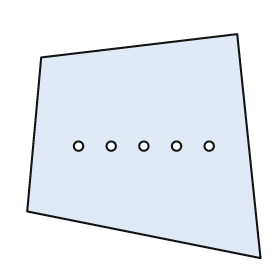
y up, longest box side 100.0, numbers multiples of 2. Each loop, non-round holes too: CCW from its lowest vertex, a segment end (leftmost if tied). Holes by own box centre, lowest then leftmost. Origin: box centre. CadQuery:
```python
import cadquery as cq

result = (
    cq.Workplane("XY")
    .moveTo(50.0, -48.0)
    .lineTo(40.0, 48.0)
    .lineTo(-44.0, 38.0)
    .lineTo(-50.0, -28.0)
    .close()
    .moveTo(-28.0, 0.0)
    .circle(2.0)
    .moveTo(-14.0, 0.0)
    .circle(2.0)
    .moveTo(0.0, 0.0)
    .circle(2.0)
    .moveTo(14.0, 0.0)
    .circle(2.0)
    .moveTo(28.0, 0.0)
    .circle(2.0)
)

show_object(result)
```